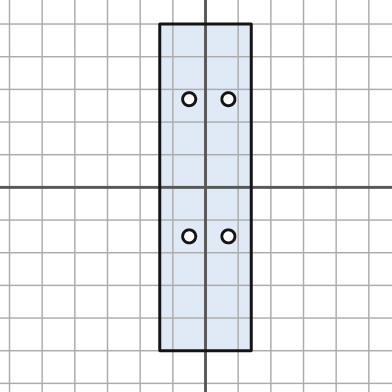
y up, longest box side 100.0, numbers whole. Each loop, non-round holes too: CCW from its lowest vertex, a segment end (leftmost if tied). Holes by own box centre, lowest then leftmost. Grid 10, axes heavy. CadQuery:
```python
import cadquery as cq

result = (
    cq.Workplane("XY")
    .moveTo(-14.0, -50.0)
    .lineTo(14.0, -50.0)
    .lineTo(14.0, 50.0)
    .lineTo(-14.0, 50.0)
    .close()
    .moveTo(-5.0, -15.0)
    .circle(2.0)
    .moveTo(7.0, -15.0)
    .circle(2.0)
    .moveTo(-5.0, 27.0)
    .circle(2.0)
    .moveTo(7.0, 27.0)
    .circle(2.0)
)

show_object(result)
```